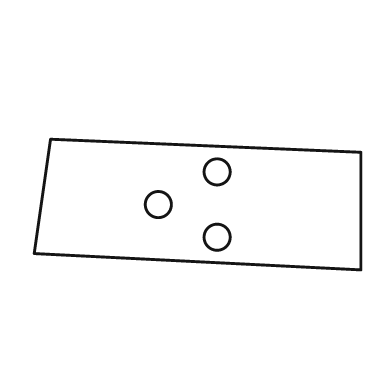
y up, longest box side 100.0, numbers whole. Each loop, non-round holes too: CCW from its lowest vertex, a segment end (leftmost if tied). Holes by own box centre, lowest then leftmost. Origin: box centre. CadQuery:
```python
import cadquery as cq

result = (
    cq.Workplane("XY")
    .moveTo(50.0, -20.0)
    .lineTo(50.0, 16.0)
    .lineTo(-45.0, 20.0)
    .lineTo(-50.0, -15.0)
    .close()
    .moveTo(6.0, -10.0)
    .circle(4.0)
    .moveTo(-12.0, 0.0)
    .circle(4.0)
    .moveTo(6.0, 10.0)
    .circle(4.0)
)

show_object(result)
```